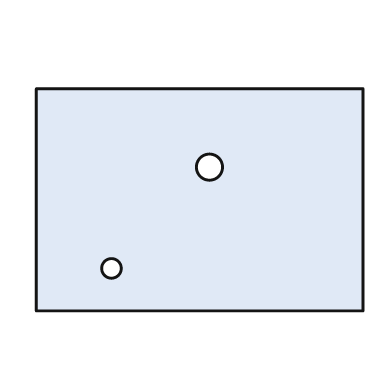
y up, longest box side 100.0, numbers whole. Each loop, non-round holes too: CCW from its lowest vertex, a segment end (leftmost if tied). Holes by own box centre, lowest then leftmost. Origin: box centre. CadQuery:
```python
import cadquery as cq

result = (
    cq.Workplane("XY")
    .moveTo(-50.0, -34.0)
    .lineTo(50.0, -34.0)
    .lineTo(50.0, 34.0)
    .lineTo(-50.0, 34.0)
    .close()
    .moveTo(-27.0, -21.0)
    .circle(3.0)
    .moveTo(3.0, 10.0)
    .circle(4.0)
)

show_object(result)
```